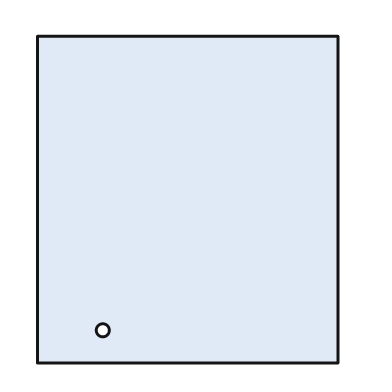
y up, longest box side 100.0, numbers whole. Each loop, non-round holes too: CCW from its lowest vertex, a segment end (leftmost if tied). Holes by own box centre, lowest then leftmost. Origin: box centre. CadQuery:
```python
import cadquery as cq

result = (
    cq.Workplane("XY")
    .moveTo(-46.0, -50.0)
    .lineTo(46.0, -50.0)
    .lineTo(46.0, 50.0)
    .lineTo(-46.0, 50.0)
    .close()
    .moveTo(-26.0, -40.0)
    .circle(2.0)
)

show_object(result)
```